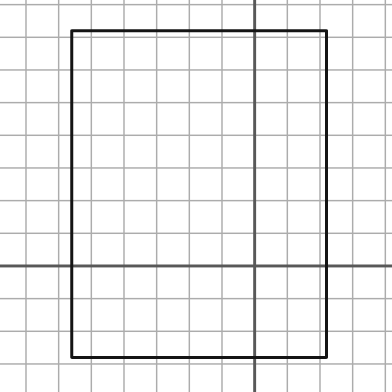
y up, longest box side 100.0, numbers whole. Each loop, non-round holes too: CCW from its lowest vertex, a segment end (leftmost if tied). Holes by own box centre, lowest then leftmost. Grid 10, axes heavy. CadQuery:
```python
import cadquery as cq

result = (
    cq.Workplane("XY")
    .moveTo(-56.0, -28.0)
    .lineTo(22.0, -28.0)
    .lineTo(22.0, 72.0)
    .lineTo(-56.0, 72.0)
    .close()
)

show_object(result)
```